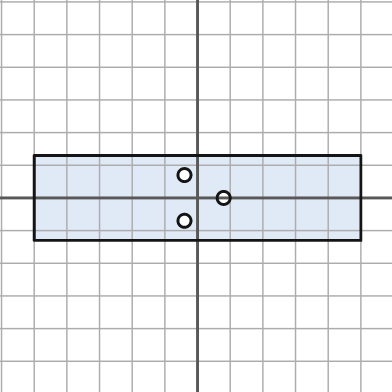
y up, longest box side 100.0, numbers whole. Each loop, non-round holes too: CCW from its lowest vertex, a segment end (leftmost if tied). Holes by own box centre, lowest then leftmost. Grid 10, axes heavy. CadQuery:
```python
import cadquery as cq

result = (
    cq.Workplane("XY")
    .moveTo(-50.0, -13.0)
    .lineTo(50.0, -13.0)
    .lineTo(50.0, 13.0)
    .lineTo(-50.0, 13.0)
    .close()
    .moveTo(-4.0, -7.0)
    .circle(2.0)
    .moveTo(8.0, 0.0)
    .circle(2.0)
    .moveTo(-4.0, 7.0)
    .circle(2.0)
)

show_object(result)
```